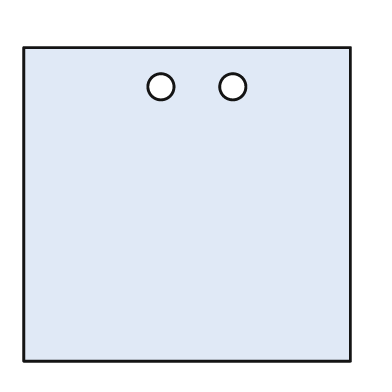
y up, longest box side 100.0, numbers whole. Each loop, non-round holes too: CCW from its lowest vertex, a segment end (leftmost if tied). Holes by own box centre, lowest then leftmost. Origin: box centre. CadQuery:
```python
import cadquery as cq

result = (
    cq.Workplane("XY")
    .moveTo(-50.0, -48.0)
    .lineTo(50.0, -48.0)
    .lineTo(50.0, 48.0)
    .lineTo(-50.0, 48.0)
    .close()
    .moveTo(-8.0, 36.0)
    .circle(4.0)
    .moveTo(14.0, 36.0)
    .circle(4.0)
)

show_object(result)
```